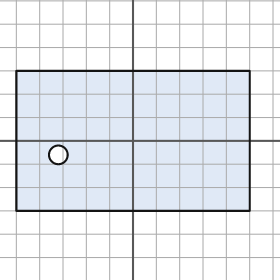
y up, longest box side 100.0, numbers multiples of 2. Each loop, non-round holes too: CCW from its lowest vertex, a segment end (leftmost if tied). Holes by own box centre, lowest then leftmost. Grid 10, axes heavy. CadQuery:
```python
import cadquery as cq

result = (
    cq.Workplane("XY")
    .moveTo(-50.0, -30.0)
    .lineTo(50.0, -30.0)
    .lineTo(50.0, 30.0)
    .lineTo(-50.0, 30.0)
    .close()
    .moveTo(-32.0, -6.0)
    .circle(4.0)
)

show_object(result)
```